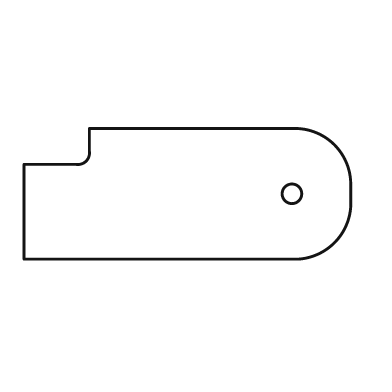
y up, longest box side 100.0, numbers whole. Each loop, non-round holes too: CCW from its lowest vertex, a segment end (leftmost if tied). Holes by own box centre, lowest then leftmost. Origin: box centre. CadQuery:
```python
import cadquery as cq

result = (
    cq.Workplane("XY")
    .moveTo(-50.0, -20.0)
    .lineTo(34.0, -20.0)
    .threePointArc((45.0, -15.0), (50.0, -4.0))
    .lineTo(50.0, 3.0)
    .threePointArc((45.0, 15.0), (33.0, 20.0))
    .lineTo(-30.0, 20.0)
    .lineTo(-30.0, 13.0)
    .threePointArc((-31.0, 10.0), (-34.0, 9.0))
    .lineTo(-50.0, 9.0)
    .close()
    .moveTo(32.0, 0.0)
    .circle(3.0)
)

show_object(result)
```